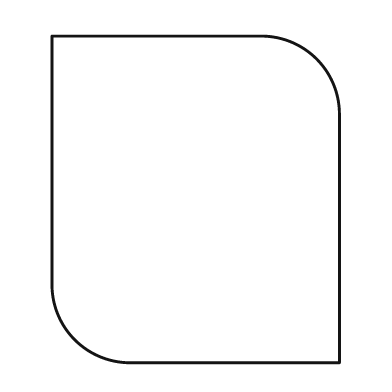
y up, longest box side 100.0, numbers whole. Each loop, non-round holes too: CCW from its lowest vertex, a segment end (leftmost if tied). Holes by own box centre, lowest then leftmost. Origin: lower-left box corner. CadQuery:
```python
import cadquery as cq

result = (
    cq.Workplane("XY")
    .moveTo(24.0, 0.0)
    .lineTo(88.0, 0.0)
    .lineTo(88.0, 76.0)
    .threePointArc((81.0, 93.0), (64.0, 100.0))
    .lineTo(0.0, 100.0)
    .lineTo(0.0, 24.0)
    .threePointArc((7.0, 7.0), (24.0, 0.0))
    .close()
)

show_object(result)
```